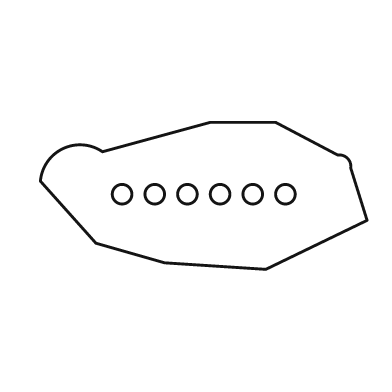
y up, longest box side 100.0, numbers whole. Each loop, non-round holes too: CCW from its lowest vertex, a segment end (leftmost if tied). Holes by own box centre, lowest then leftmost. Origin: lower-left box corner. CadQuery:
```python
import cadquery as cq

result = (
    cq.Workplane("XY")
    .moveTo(69.0, 0.0)
    .lineTo(100.0, 15.0)
    .lineTo(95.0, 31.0)
    .threePointArc((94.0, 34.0), (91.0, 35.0))
    .lineTo(72.0, 45.0)
    .lineTo(52.0, 45.0)
    .lineTo(19.0, 36.0)
    .threePointArc((7.0, 37.0), (0.0, 27.0))
    .lineTo(17.0, 8.0)
    .lineTo(38.0, 2.0)
    .close()
    .moveTo(25.0, 23.0)
    .circle(3.0)
    .moveTo(35.0, 23.0)
    .circle(3.0)
    .moveTo(45.0, 23.0)
    .circle(3.0)
    .moveTo(55.0, 23.0)
    .circle(3.0)
    .moveTo(65.0, 23.0)
    .circle(3.0)
    .moveTo(75.0, 23.0)
    .circle(3.0)
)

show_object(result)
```